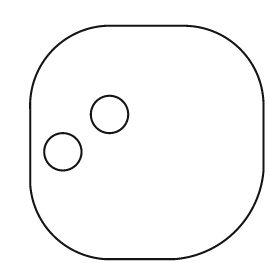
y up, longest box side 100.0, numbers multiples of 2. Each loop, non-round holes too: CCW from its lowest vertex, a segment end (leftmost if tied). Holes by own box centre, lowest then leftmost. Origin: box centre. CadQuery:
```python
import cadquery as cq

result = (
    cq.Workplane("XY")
    .moveTo(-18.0, -50.0)
    .lineTo(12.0, -50.0)
    .threePointArc((38.0, -38.0), (50.0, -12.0))
    .lineTo(50.0, 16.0)
    .threePointArc((40.0, 40.0), (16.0, 50.0))
    .lineTo(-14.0, 50.0)
    .threePointArc((-40.0, 40.0), (-50.0, 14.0))
    .lineTo(-50.0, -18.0)
    .threePointArc((-40.0, -40.0), (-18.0, -50.0))
    .close()
    .moveTo(-36.0, -4.0)
    .circle(8.0)
    .moveTo(-16.0, 12.0)
    .circle(8.0)
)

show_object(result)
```